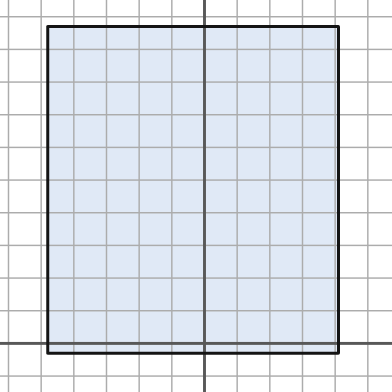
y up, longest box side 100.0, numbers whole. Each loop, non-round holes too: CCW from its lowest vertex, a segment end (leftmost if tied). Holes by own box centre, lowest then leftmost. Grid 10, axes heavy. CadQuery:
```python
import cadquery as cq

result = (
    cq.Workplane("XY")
    .moveTo(-48.0, -3.0)
    .lineTo(41.0, -3.0)
    .lineTo(41.0, 97.0)
    .lineTo(-48.0, 97.0)
    .close()
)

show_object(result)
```